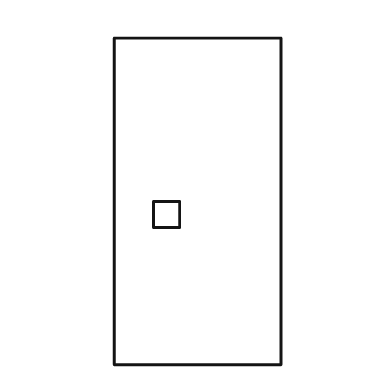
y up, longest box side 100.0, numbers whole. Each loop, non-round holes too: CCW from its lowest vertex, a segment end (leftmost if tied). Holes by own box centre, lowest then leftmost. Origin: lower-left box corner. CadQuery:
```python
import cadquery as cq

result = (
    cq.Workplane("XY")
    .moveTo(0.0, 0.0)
    .lineTo(51.0, 0.0)
    .lineTo(51.0, 100.0)
    .lineTo(0.0, 100.0)
    .close()
    .moveTo(12.0, 42.0)
    .lineTo(20.0, 42.0)
    .lineTo(20.0, 50.0)
    .lineTo(12.0, 50.0)
    .close()
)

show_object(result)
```